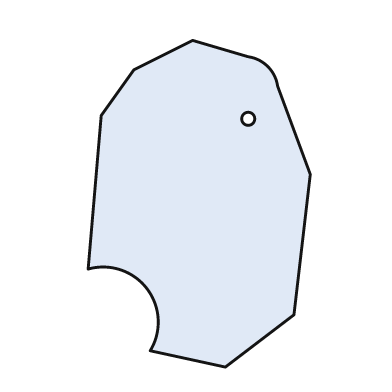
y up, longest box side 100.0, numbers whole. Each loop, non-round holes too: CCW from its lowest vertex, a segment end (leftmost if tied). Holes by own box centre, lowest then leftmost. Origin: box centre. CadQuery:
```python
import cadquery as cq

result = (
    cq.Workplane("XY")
    .moveTo(8.0, -50.0)
    .lineTo(29.0, -34.0)
    .lineTo(34.0, 9.0)
    .lineTo(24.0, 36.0)
    .threePointArc((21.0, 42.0), (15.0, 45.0))
    .lineTo(-2.0, 50.0)
    .lineTo(-20.0, 41.0)
    .lineTo(-30.0, 27.0)
    .lineTo(-34.0, -20.0)
    .threePointArc((-16.0, -26.0), (-15.0, -45.0))
    .close()
    .moveTo(15.0, 26.0)
    .circle(2.0)
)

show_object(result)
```